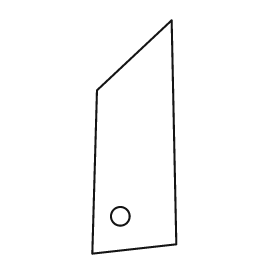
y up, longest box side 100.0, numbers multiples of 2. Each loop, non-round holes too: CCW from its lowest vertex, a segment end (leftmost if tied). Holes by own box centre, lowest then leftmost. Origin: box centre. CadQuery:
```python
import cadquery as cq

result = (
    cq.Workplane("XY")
    .moveTo(-18.0, -50.0)
    .lineTo(18.0, -46.0)
    .lineTo(16.0, 50.0)
    .lineTo(-16.0, 20.0)
    .close()
    .moveTo(-6.0, -34.0)
    .circle(4.0)
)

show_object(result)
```